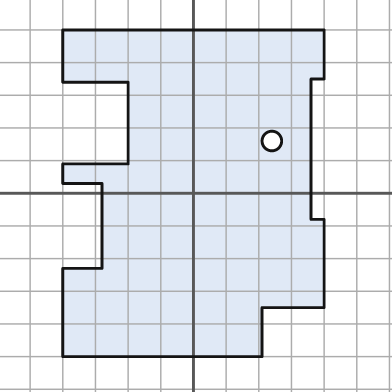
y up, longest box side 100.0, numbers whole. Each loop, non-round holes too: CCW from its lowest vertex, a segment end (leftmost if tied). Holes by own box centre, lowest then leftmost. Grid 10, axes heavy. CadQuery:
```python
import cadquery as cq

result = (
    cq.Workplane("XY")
    .moveTo(-40.0, -50.0)
    .lineTo(21.0, -50.0)
    .lineTo(21.0, -35.0)
    .lineTo(40.0, -35.0)
    .lineTo(40.0, -8.0)
    .lineTo(36.0, -8.0)
    .lineTo(36.0, 35.0)
    .lineTo(40.0, 35.0)
    .lineTo(40.0, 50.0)
    .lineTo(-40.0, 50.0)
    .lineTo(-40.0, 34.0)
    .lineTo(-20.0, 34.0)
    .lineTo(-20.0, 9.0)
    .lineTo(-40.0, 9.0)
    .lineTo(-40.0, 3.0)
    .lineTo(-28.0, 3.0)
    .lineTo(-28.0, -23.0)
    .lineTo(-40.0, -23.0)
    .close()
    .moveTo(24.0, 16.0)
    .circle(3.0)
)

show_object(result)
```